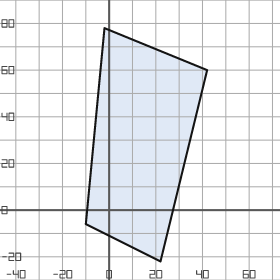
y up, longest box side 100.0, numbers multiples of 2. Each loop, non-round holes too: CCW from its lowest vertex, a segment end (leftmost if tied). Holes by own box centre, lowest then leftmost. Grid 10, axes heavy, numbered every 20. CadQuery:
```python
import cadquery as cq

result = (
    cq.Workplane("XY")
    .moveTo(22.0, -22.0)
    .lineTo(42.0, 60.0)
    .lineTo(-2.0, 78.0)
    .lineTo(-10.0, -6.0)
    .close()
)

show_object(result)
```